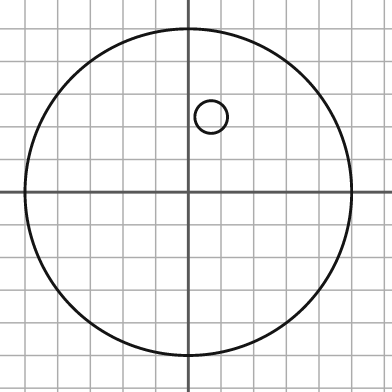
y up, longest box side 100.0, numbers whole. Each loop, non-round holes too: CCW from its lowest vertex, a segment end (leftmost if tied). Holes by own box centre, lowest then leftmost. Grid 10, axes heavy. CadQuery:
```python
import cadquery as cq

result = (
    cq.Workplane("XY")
    .moveTo(0.0, 0.0)
    .circle(50.0)
    .moveTo(7.0, 23.0)
    .circle(5.0)
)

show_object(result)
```